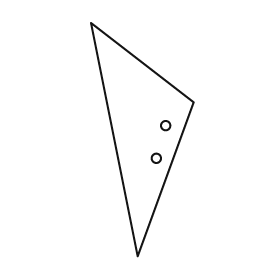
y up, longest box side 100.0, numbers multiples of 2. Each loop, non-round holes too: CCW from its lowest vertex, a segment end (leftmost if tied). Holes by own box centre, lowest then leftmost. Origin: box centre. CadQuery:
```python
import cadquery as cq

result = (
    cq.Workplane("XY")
    .moveTo(-2.0, -50.0)
    .lineTo(22.0, 16.0)
    .lineTo(-22.0, 50.0)
    .close()
    .moveTo(6.0, -8.0)
    .circle(2.0)
    .moveTo(10.0, 6.0)
    .circle(2.0)
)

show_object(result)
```